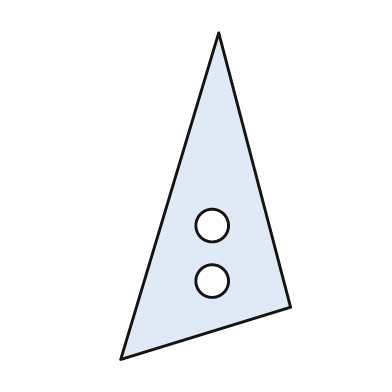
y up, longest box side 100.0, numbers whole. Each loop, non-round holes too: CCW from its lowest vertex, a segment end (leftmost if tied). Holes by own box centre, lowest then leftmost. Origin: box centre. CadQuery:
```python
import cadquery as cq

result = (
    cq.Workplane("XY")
    .moveTo(-26.0, -50.0)
    .lineTo(26.0, -34.0)
    .lineTo(4.0, 50.0)
    .close()
    .moveTo(2.0, -26.0)
    .circle(5.0)
    .moveTo(2.0, -9.0)
    .circle(5.0)
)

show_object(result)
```